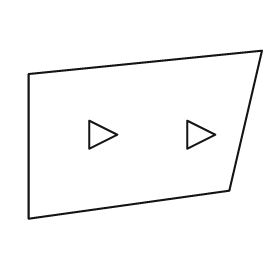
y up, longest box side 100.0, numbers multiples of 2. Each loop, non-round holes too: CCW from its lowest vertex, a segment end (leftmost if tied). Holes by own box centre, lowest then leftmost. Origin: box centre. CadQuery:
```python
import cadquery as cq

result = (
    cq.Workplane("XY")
    .moveTo(-50.0, -36.0)
    .lineTo(36.0, -24.0)
    .lineTo(50.0, 36.0)
    .lineTo(-50.0, 26.0)
    .close()
    .moveTo(-24.0, -6.0)
    .lineTo(-12.0, 0.0)
    .lineTo(-24.0, 6.0)
    .close()
    .moveTo(18.0, -6.0)
    .lineTo(30.0, 0.0)
    .lineTo(18.0, 6.0)
    .close()
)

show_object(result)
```